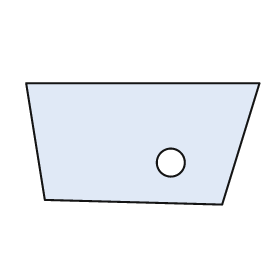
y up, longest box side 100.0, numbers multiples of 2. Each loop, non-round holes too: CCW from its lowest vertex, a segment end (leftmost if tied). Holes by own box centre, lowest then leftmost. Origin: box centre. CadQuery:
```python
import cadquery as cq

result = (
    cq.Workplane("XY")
    .moveTo(34.0, -26.0)
    .lineTo(50.0, 26.0)
    .lineTo(-50.0, 26.0)
    .lineTo(-42.0, -24.0)
    .close()
    .moveTo(12.0, -8.0)
    .circle(6.0)
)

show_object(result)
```